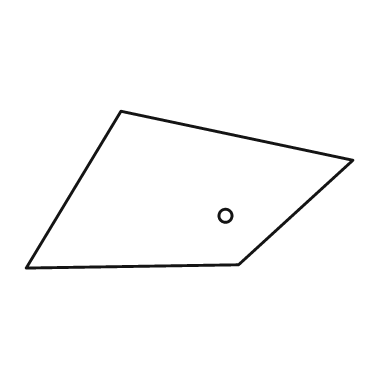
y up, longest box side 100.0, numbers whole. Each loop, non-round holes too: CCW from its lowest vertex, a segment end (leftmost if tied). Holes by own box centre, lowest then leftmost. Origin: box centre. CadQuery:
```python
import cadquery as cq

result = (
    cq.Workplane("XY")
    .moveTo(-50.0, -24.0)
    .lineTo(15.0, -23.0)
    .lineTo(50.0, 9.0)
    .lineTo(-21.0, 24.0)
    .close()
    .moveTo(11.0, -8.0)
    .circle(2.0)
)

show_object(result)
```